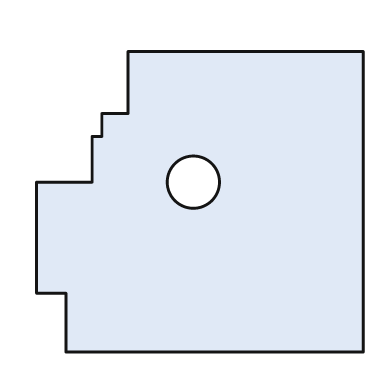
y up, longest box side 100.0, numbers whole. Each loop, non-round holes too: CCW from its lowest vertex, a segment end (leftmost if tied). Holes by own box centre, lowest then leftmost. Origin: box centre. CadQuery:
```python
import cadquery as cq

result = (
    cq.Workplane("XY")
    .moveTo(-41.0, -46.0)
    .lineTo(50.0, -46.0)
    .lineTo(50.0, 46.0)
    .lineTo(-22.0, 46.0)
    .lineTo(-22.0, 27.0)
    .lineTo(-30.0, 27.0)
    .lineTo(-30.0, 20.0)
    .lineTo(-33.0, 20.0)
    .lineTo(-33.0, 6.0)
    .lineTo(-50.0, 6.0)
    .lineTo(-50.0, -28.0)
    .lineTo(-41.0, -28.0)
    .close()
    .moveTo(-2.0, 6.0)
    .circle(8.0)
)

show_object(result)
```